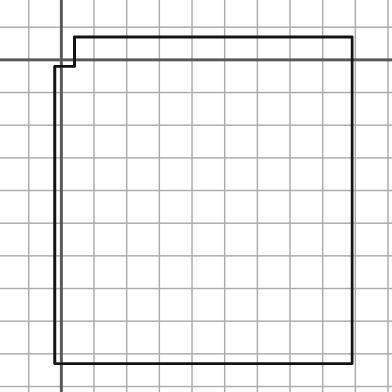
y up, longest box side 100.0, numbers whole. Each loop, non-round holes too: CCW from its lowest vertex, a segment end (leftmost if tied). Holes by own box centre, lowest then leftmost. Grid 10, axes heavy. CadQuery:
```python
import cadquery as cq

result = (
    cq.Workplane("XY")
    .moveTo(-2.0, -93.0)
    .lineTo(89.0, -93.0)
    .lineTo(89.0, 7.0)
    .lineTo(4.0, 7.0)
    .lineTo(4.0, -2.0)
    .lineTo(-2.0, -2.0)
    .close()
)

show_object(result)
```